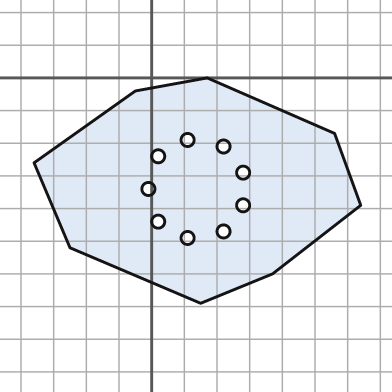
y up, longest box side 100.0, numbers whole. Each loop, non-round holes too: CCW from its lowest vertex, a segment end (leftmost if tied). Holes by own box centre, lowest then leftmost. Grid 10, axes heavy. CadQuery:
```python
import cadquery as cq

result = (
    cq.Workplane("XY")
    .moveTo(15.0, -69.0)
    .lineTo(37.0, -60.0)
    .lineTo(64.0, -39.0)
    .lineTo(56.0, -17.0)
    .lineTo(17.0, 0.0)
    .lineTo(-5.0, -4.0)
    .lineTo(-36.0, -26.0)
    .lineTo(-25.0, -52.0)
    .close()
    .moveTo(11.0, -49.0)
    .circle(2.0)
    .moveTo(22.0, -47.0)
    .circle(2.0)
    .moveTo(2.0, -44.0)
    .circle(2.0)
    .moveTo(28.0, -39.0)
    .circle(2.0)
    .moveTo(-1.0, -34.0)
    .circle(2.0)
    .moveTo(28.0, -29.0)
    .circle(2.0)
    .moveTo(2.0, -24.0)
    .circle(2.0)
    .moveTo(22.0, -21.0)
    .circle(2.0)
    .moveTo(11.0, -19.0)
    .circle(2.0)
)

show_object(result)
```